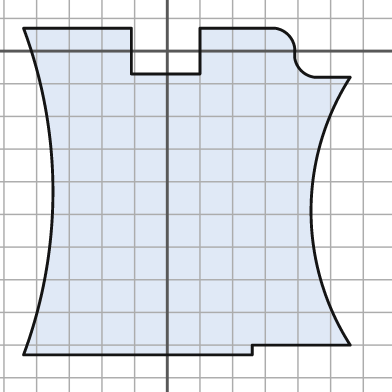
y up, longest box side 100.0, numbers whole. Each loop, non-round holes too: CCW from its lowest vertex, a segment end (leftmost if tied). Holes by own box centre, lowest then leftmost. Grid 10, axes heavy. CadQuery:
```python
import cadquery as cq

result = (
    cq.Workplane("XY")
    .moveTo(-44.0, -93.0)
    .lineTo(26.0, -93.0)
    .lineTo(26.0, -90.0)
    .lineTo(56.0, -90.0)
    .threePointArc((44.0, -49.0), (56.0, -8.0))
    .lineTo(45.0, -8.0)
    .threePointArc((41.0, -6.0), (39.0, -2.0))
    .lineTo(39.0, 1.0)
    .threePointArc((37.0, 5.0), (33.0, 7.0))
    .lineTo(10.0, 7.0)
    .lineTo(10.0, -7.0)
    .lineTo(-11.0, -7.0)
    .lineTo(-11.0, 7.0)
    .lineTo(-44.0, 7.0)
    .threePointArc((-35.0, -43.0), (-44.0, -93.0))
    .close()
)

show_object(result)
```